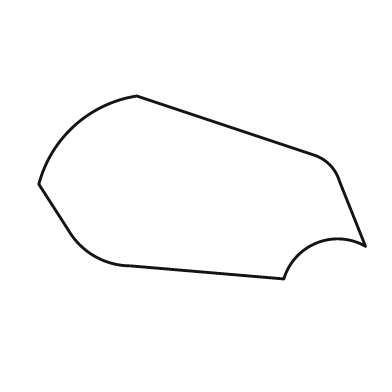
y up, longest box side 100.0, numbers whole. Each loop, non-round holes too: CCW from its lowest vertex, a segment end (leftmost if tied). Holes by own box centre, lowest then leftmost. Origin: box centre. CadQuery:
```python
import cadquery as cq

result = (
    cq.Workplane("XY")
    .moveTo(25.0, -28.0)
    .threePointArc((35.0, -17.0), (50.0, -18.0))
    .lineTo(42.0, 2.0)
    .threePointArc((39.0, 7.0), (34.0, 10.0))
    .lineTo(-20.0, 28.0)
    .threePointArc((-39.0, 19.0), (-50.0, 1.0))
    .lineTo(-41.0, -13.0)
    .threePointArc((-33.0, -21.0), (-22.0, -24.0))
    .close()
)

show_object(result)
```